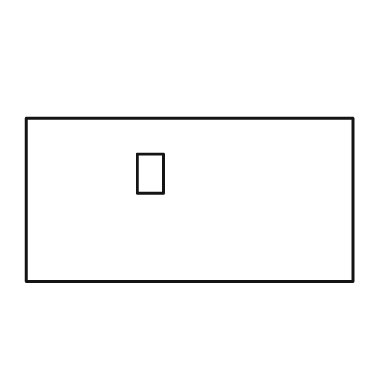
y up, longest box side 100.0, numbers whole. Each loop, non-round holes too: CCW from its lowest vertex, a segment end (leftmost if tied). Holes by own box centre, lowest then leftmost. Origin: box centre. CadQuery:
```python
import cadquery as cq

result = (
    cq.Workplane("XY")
    .moveTo(-50.0, -25.0)
    .lineTo(50.0, -25.0)
    .lineTo(50.0, 25.0)
    .lineTo(-50.0, 25.0)
    .close()
    .moveTo(-16.0, 2.0)
    .lineTo(-8.0, 2.0)
    .lineTo(-8.0, 14.0)
    .lineTo(-16.0, 14.0)
    .close()
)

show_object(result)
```